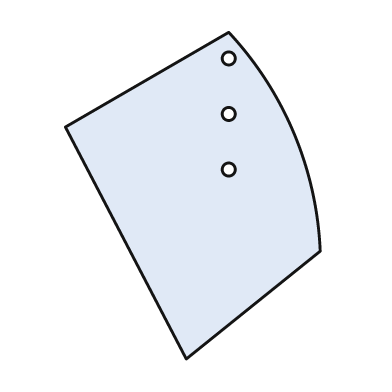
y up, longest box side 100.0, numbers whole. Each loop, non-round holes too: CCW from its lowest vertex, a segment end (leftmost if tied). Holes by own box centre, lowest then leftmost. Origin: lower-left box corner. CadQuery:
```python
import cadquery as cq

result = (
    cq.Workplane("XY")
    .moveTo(37.0, 0.0)
    .lineTo(78.0, 33.0)
    .threePointArc((70.0, 69.0), (50.0, 100.0))
    .lineTo(0.0, 71.0)
    .close()
    .moveTo(50.0, 58.0)
    .circle(2.0)
    .moveTo(50.0, 75.0)
    .circle(2.0)
    .moveTo(50.0, 92.0)
    .circle(2.0)
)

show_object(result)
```